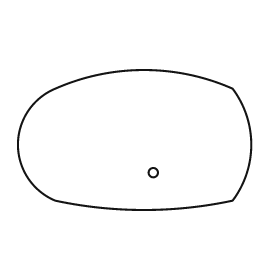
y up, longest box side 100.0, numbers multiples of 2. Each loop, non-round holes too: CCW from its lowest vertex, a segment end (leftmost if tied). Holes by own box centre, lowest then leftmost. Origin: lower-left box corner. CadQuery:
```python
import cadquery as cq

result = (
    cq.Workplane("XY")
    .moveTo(16.0, 4.0)
    .threePointArc((54.0, 0.0), (92.0, 4.0))
    .threePointArc((100.0, 28.0), (92.0, 52.0))
    .threePointArc((54.0, 60.0), (16.0, 52.0))
    .threePointArc((0.0, 28.0), (16.0, 4.0))
    .close()
    .moveTo(58.0, 16.0)
    .circle(2.0)
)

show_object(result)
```